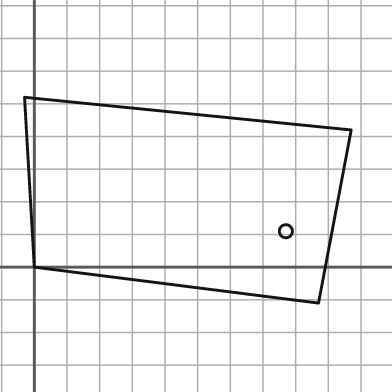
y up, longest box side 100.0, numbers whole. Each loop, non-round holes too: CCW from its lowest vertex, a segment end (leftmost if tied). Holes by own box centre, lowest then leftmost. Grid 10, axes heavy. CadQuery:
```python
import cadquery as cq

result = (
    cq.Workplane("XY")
    .moveTo(87.0, -11.0)
    .lineTo(97.0, 42.0)
    .lineTo(-3.0, 52.0)
    .lineTo(0.0, 0.0)
    .close()
    .moveTo(77.0, 11.0)
    .circle(2.0)
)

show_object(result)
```